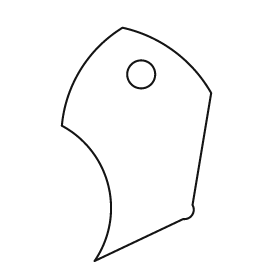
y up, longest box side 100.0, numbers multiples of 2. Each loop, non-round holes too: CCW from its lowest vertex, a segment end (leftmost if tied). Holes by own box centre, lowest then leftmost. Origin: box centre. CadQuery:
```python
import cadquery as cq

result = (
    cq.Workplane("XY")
    .moveTo(-18.0, -50.0)
    .lineTo(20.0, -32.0)
    .threePointArc((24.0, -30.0), (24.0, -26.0))
    .lineTo(32.0, 22.0)
    .threePointArc((16.0, 40.0), (-6.0, 50.0))
    .threePointArc((-24.0, 32.0), (-32.0, 8.0))
    .threePointArc((-12.0, -18.0), (-18.0, -50.0))
    .close()
    .moveTo(2.0, 30.0)
    .circle(6.0)
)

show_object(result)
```